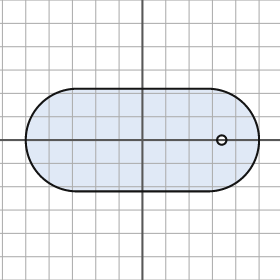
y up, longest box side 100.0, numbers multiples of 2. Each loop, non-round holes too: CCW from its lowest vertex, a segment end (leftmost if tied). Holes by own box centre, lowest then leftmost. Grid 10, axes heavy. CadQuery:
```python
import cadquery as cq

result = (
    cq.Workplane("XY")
    .moveTo(-28.0, -22.0)
    .lineTo(28.0, -22.0)
    .threePointArc((50.0, 0.0), (28.0, 22.0))
    .lineTo(-28.0, 22.0)
    .threePointArc((-50.0, 0.0), (-28.0, -22.0))
    .close()
    .moveTo(34.0, 0.0)
    .circle(2.0)
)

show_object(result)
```